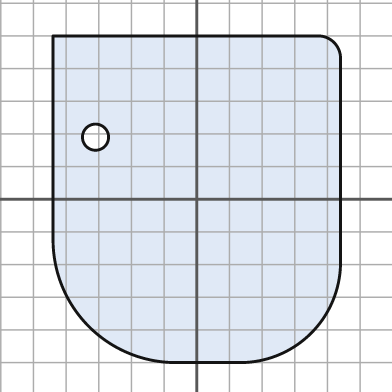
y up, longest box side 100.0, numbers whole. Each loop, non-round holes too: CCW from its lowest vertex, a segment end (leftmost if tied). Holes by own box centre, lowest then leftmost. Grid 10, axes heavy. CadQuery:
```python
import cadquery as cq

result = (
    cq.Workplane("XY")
    .moveTo(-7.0, -50.0)
    .lineTo(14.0, -50.0)
    .threePointArc((35.0, -41.0), (44.0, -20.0))
    .lineTo(44.0, 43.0)
    .threePointArc((42.0, 48.0), (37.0, 50.0))
    .lineTo(-44.0, 50.0)
    .lineTo(-44.0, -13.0)
    .threePointArc((-33.0, -39.0), (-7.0, -50.0))
    .close()
    .moveTo(-31.0, 19.0)
    .circle(4.0)
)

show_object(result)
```